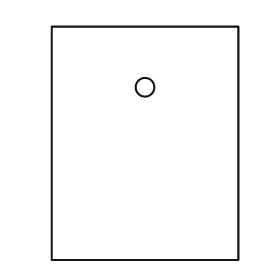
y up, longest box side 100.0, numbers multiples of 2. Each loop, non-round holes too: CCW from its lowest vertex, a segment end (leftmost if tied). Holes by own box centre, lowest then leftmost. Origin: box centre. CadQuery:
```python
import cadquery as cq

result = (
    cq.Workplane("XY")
    .moveTo(-40.0, -50.0)
    .lineTo(40.0, -50.0)
    .lineTo(40.0, 50.0)
    .lineTo(-40.0, 50.0)
    .close()
    .moveTo(0.0, 24.0)
    .circle(4.0)
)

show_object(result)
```